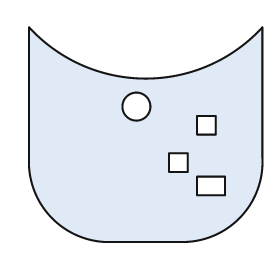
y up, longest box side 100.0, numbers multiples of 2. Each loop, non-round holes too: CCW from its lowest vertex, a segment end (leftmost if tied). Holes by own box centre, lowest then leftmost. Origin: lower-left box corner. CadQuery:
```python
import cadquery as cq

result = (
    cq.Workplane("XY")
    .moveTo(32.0, 0.0)
    .lineTo(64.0, 0.0)
    .threePointArc((90.0, 10.0), (100.0, 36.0))
    .lineTo(100.0, 92.0)
    .threePointArc((50.0, 70.0), (0.0, 92.0))
    .lineTo(0.0, 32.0)
    .threePointArc((10.0, 10.0), (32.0, 0.0))
    .close()
    .moveTo(72.0, 20.0)
    .lineTo(84.0, 20.0)
    .lineTo(84.0, 28.0)
    .lineTo(72.0, 28.0)
    .close()
    .moveTo(60.0, 30.0)
    .lineTo(68.0, 30.0)
    .lineTo(68.0, 38.0)
    .lineTo(60.0, 38.0)
    .close()
    .moveTo(72.0, 46.0)
    .lineTo(80.0, 46.0)
    .lineTo(80.0, 54.0)
    .lineTo(72.0, 54.0)
    .close()
    .moveTo(46.0, 58.0)
    .circle(6.0)
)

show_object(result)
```